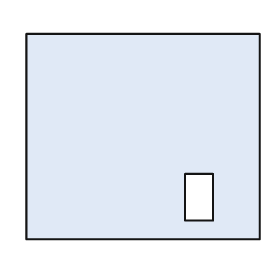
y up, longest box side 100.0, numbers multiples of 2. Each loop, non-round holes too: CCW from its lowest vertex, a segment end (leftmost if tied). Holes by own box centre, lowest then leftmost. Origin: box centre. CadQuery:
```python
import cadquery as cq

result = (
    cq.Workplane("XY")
    .moveTo(-50.0, -44.0)
    .lineTo(50.0, -44.0)
    .lineTo(50.0, 44.0)
    .lineTo(-50.0, 44.0)
    .close()
    .moveTo(18.0, -36.0)
    .lineTo(30.0, -36.0)
    .lineTo(30.0, -16.0)
    .lineTo(18.0, -16.0)
    .close()
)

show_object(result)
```